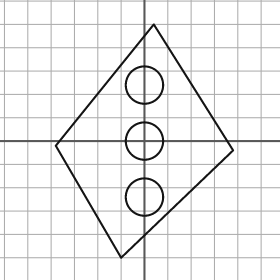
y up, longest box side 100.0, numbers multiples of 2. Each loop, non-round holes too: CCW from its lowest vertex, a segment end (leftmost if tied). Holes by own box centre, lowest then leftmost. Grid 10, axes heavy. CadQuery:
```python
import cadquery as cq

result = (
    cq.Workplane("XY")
    .moveTo(-10.0, -50.0)
    .lineTo(38.0, -4.0)
    .lineTo(4.0, 50.0)
    .lineTo(-38.0, -2.0)
    .close()
    .moveTo(0.0, -24.0)
    .circle(8.0)
    .moveTo(0.0, 0.0)
    .circle(8.0)
    .moveTo(0.0, 24.0)
    .circle(8.0)
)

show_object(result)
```